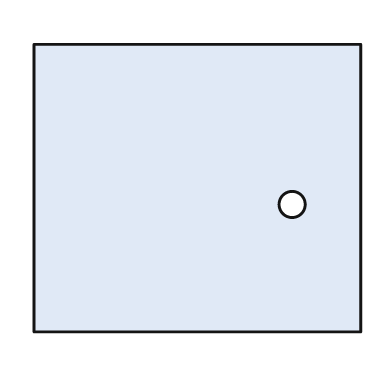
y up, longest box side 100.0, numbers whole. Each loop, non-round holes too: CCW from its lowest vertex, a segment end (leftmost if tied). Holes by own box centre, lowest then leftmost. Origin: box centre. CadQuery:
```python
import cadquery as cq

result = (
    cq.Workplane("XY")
    .moveTo(-50.0, -44.0)
    .lineTo(50.0, -44.0)
    .lineTo(50.0, 44.0)
    .lineTo(-50.0, 44.0)
    .close()
    .moveTo(29.0, -5.0)
    .circle(4.0)
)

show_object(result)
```